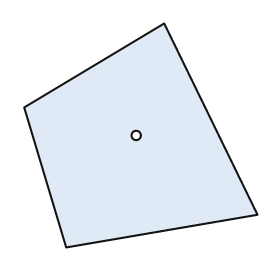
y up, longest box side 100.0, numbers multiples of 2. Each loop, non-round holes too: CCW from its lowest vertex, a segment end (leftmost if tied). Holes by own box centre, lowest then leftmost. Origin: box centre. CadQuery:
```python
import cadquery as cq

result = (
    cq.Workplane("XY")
    .moveTo(-32.0, -48.0)
    .lineTo(50.0, -34.0)
    .lineTo(10.0, 48.0)
    .lineTo(-50.0, 12.0)
    .close()
    .moveTo(-2.0, 0.0)
    .circle(2.0)
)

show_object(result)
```